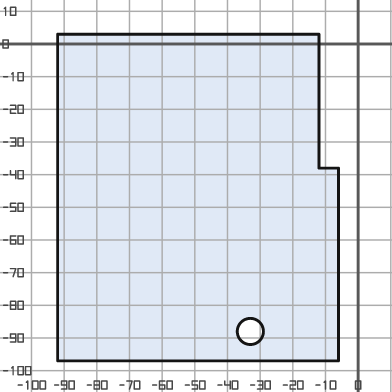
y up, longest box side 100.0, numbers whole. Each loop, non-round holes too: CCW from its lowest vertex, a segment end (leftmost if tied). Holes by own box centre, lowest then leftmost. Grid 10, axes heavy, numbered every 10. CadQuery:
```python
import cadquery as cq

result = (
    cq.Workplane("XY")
    .moveTo(-92.0, -97.0)
    .lineTo(-6.0, -97.0)
    .lineTo(-6.0, -38.0)
    .lineTo(-12.0, -38.0)
    .lineTo(-12.0, 3.0)
    .lineTo(-92.0, 3.0)
    .close()
    .moveTo(-33.0, -88.0)
    .circle(4.0)
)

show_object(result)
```